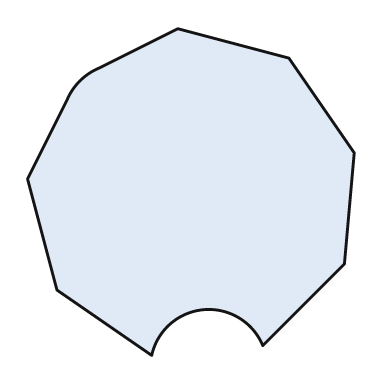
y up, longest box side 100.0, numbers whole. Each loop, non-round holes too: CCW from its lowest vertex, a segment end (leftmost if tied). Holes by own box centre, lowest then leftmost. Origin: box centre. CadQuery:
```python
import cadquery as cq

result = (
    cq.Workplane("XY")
    .moveTo(-12.0, -50.0)
    .threePointArc((4.0, -36.0), (22.0, -47.0))
    .lineTo(47.0, -22.0)
    .lineTo(50.0, 12.0)
    .lineTo(30.0, 41.0)
    .lineTo(-4.0, 50.0)
    .lineTo(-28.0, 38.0)
    .threePointArc((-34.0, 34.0), (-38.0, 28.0))
    .lineTo(-50.0, 4.0)
    .lineTo(-41.0, -30.0)
    .close()
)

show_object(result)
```